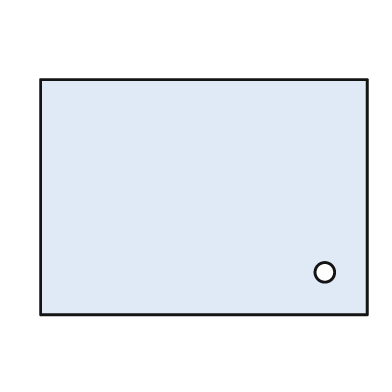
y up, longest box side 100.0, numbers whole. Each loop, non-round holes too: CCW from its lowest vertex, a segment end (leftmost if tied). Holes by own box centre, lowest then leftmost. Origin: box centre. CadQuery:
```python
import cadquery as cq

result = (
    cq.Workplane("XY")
    .moveTo(-50.0, -36.0)
    .lineTo(50.0, -36.0)
    .lineTo(50.0, 36.0)
    .lineTo(-50.0, 36.0)
    .close()
    .moveTo(37.0, -23.0)
    .circle(3.0)
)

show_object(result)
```